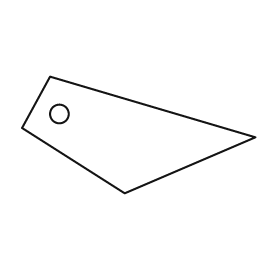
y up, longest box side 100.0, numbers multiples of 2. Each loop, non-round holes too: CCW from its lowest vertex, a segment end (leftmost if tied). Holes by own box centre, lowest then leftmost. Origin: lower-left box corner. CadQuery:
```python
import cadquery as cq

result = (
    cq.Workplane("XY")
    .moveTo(44.0, 0.0)
    .lineTo(100.0, 24.0)
    .lineTo(12.0, 50.0)
    .lineTo(0.0, 28.0)
    .close()
    .moveTo(16.0, 34.0)
    .circle(4.0)
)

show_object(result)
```